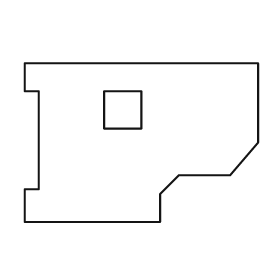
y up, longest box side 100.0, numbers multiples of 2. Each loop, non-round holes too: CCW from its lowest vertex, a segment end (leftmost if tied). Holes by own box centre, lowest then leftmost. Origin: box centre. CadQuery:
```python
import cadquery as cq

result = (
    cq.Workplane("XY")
    .moveTo(-50.0, -34.0)
    .lineTo(8.0, -34.0)
    .lineTo(8.0, -22.0)
    .lineTo(16.0, -14.0)
    .lineTo(38.0, -14.0)
    .lineTo(50.0, 0.0)
    .lineTo(50.0, 34.0)
    .lineTo(-50.0, 34.0)
    .lineTo(-50.0, 22.0)
    .lineTo(-44.0, 22.0)
    .lineTo(-44.0, -20.0)
    .lineTo(-50.0, -20.0)
    .close()
    .moveTo(-16.0, 6.0)
    .lineTo(0.0, 6.0)
    .lineTo(0.0, 22.0)
    .lineTo(-16.0, 22.0)
    .close()
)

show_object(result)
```